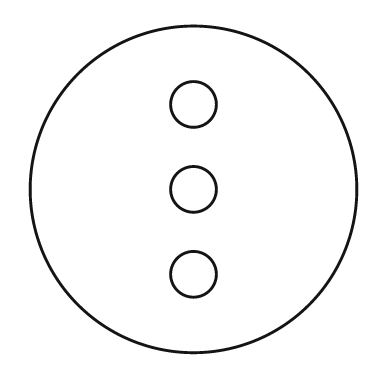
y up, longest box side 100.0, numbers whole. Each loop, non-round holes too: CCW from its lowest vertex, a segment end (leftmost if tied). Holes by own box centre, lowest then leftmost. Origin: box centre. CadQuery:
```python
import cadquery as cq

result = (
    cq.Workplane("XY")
    .moveTo(0.0, 0.0)
    .circle(50.0)
    .moveTo(0.0, -26.0)
    .circle(7.0)
    .moveTo(0.0, 0.0)
    .circle(7.0)
    .moveTo(0.0, 26.0)
    .circle(7.0)
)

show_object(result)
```